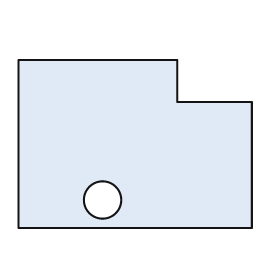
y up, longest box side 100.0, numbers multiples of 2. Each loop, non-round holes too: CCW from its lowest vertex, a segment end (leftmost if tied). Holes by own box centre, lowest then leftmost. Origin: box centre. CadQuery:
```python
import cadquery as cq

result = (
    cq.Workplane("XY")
    .moveTo(-50.0, -36.0)
    .lineTo(50.0, -36.0)
    .lineTo(50.0, 18.0)
    .lineTo(18.0, 18.0)
    .lineTo(18.0, 36.0)
    .lineTo(-50.0, 36.0)
    .close()
    .moveTo(-14.0, -24.0)
    .circle(8.0)
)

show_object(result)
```